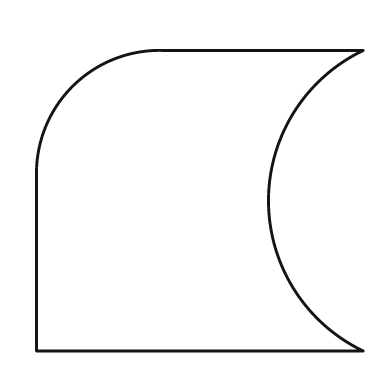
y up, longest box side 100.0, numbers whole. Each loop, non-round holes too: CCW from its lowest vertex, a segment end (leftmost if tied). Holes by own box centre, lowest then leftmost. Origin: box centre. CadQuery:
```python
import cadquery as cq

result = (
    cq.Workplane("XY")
    .moveTo(-50.0, -46.0)
    .lineTo(50.0, -46.0)
    .threePointArc((21.0, 0.0), (50.0, 46.0))
    .lineTo(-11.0, 46.0)
    .threePointArc((-39.0, 35.0), (-50.0, 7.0))
    .close()
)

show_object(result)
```